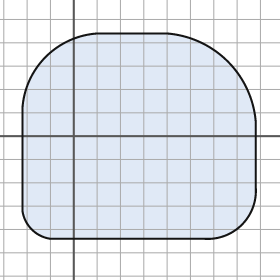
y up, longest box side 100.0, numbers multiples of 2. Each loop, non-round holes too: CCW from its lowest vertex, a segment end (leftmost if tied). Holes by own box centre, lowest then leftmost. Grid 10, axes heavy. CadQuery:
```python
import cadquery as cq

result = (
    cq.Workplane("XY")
    .moveTo(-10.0, -44.0)
    .lineTo(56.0, -44.0)
    .threePointArc((72.0, -38.0), (78.0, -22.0))
    .lineTo(78.0, 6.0)
    .threePointArc((66.0, 32.0), (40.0, 44.0))
    .lineTo(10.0, 44.0)
    .threePointArc((-12.0, 34.0), (-22.0, 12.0))
    .lineTo(-22.0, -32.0)
    .threePointArc((-18.0, -40.0), (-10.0, -44.0))
    .close()
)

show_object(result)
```